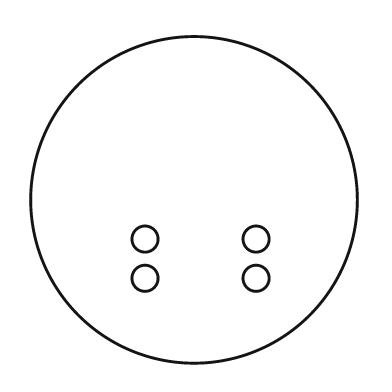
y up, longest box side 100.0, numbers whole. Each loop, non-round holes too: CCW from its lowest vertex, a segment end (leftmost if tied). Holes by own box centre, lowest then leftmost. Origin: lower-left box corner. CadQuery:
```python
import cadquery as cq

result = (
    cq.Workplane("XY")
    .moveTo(50.0, 50.0)
    .circle(50.0)
    .moveTo(35.0, 26.0)
    .circle(4.0)
    .moveTo(69.0, 26.0)
    .circle(4.0)
    .moveTo(35.0, 38.0)
    .circle(4.0)
    .moveTo(69.0, 38.0)
    .circle(4.0)
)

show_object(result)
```